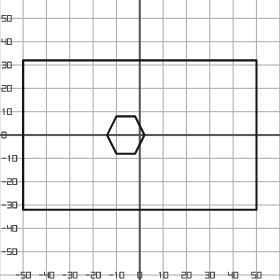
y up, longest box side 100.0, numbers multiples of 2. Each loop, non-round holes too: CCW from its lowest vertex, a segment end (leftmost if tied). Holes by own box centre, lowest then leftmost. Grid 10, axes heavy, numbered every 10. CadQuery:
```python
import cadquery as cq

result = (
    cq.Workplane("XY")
    .moveTo(-50.0, -32.0)
    .lineTo(50.0, -32.0)
    .lineTo(50.0, 32.0)
    .lineTo(-50.0, 32.0)
    .close()
    .moveTo(-10.0, -8.0)
    .lineTo(-2.0, -8.0)
    .lineTo(2.0, 0.0)
    .lineTo(-2.0, 8.0)
    .lineTo(-10.0, 8.0)
    .lineTo(-14.0, 0.0)
    .close()
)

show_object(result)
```